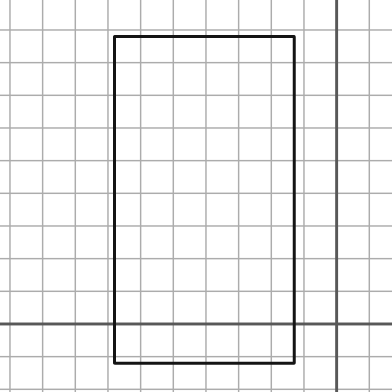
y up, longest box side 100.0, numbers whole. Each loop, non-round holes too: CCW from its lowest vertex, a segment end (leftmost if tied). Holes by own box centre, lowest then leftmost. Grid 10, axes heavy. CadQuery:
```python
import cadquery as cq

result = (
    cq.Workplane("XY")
    .moveTo(-68.0, -12.0)
    .lineTo(-13.0, -12.0)
    .lineTo(-13.0, 88.0)
    .lineTo(-68.0, 88.0)
    .close()
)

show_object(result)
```